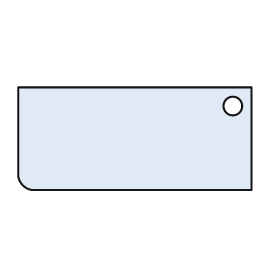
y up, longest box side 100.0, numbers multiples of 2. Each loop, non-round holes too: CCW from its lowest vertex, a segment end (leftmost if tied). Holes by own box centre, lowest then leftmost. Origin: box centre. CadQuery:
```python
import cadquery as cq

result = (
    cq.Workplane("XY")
    .moveTo(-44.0, -22.0)
    .lineTo(50.0, -22.0)
    .lineTo(50.0, 22.0)
    .lineTo(-50.0, 22.0)
    .lineTo(-50.0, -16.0)
    .threePointArc((-48.0, -20.0), (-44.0, -22.0))
    .close()
    .moveTo(42.0, 14.0)
    .circle(4.0)
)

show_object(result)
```